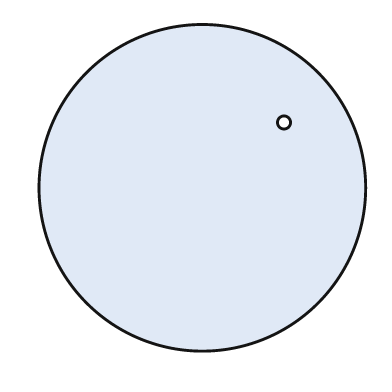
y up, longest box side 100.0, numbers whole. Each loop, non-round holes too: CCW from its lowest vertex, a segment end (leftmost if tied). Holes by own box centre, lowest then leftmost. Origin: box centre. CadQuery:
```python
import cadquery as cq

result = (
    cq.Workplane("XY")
    .moveTo(0.0, 0.0)
    .circle(50.0)
    .moveTo(25.0, 20.0)
    .circle(2.0)
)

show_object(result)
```